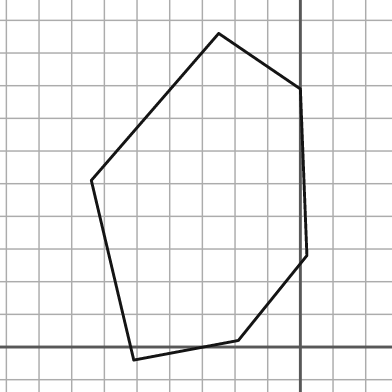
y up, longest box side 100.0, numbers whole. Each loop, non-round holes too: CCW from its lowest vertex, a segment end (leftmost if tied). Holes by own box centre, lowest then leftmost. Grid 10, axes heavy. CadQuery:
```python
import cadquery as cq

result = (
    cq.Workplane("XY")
    .moveTo(-51.0, -4.0)
    .lineTo(-19.0, 2.0)
    .lineTo(2.0, 28.0)
    .lineTo(0.0, 79.0)
    .lineTo(-25.0, 96.0)
    .lineTo(-64.0, 51.0)
    .close()
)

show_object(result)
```